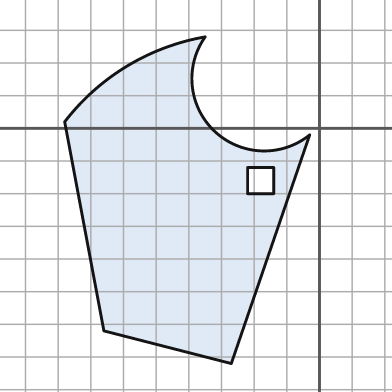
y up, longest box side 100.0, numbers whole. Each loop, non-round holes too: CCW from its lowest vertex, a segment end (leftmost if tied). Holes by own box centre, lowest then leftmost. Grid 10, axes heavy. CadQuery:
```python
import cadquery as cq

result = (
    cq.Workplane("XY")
    .moveTo(-27.0, -72.0)
    .lineTo(-3.0, -2.0)
    .threePointArc((-32.0, -1.0), (-35.0, 28.0))
    .threePointArc((-59.0, 19.0), (-78.0, 2.0))
    .lineTo(-66.0, -62.0)
    .close()
    .moveTo(-22.0, -20.0)
    .lineTo(-14.0, -20.0)
    .lineTo(-14.0, -12.0)
    .lineTo(-22.0, -12.0)
    .close()
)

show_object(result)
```